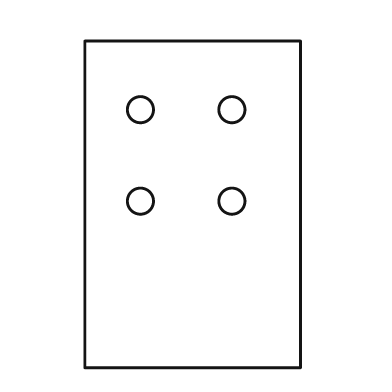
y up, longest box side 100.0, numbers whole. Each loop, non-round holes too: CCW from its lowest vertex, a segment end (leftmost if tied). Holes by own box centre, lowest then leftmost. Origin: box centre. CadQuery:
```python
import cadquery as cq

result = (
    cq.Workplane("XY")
    .moveTo(-33.0, -50.0)
    .lineTo(33.0, -50.0)
    .lineTo(33.0, 50.0)
    .lineTo(-33.0, 50.0)
    .close()
    .moveTo(-16.0, 1.0)
    .circle(4.0)
    .moveTo(12.0, 1.0)
    .circle(4.0)
    .moveTo(-16.0, 29.0)
    .circle(4.0)
    .moveTo(12.0, 29.0)
    .circle(4.0)
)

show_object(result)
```